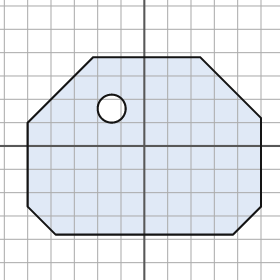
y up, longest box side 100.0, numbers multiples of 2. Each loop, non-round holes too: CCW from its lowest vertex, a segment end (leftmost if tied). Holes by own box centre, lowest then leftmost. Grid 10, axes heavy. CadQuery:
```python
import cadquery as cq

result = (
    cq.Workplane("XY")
    .moveTo(-38.0, -38.0)
    .lineTo(38.0, -38.0)
    .lineTo(50.0, -26.0)
    .lineTo(50.0, 12.0)
    .lineTo(24.0, 38.0)
    .lineTo(-22.0, 38.0)
    .lineTo(-50.0, 10.0)
    .lineTo(-50.0, -26.0)
    .close()
    .moveTo(-14.0, 16.0)
    .circle(6.0)
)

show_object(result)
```